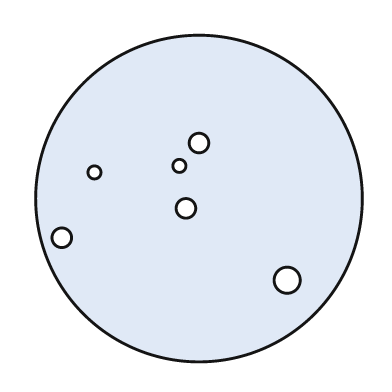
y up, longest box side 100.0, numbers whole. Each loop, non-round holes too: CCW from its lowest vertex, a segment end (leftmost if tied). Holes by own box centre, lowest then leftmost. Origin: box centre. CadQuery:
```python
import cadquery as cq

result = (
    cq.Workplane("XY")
    .moveTo(0.0, 0.0)
    .circle(50.0)
    .moveTo(27.0, -25.0)
    .circle(4.0)
    .moveTo(-42.0, -12.0)
    .circle(3.0)
    .moveTo(-4.0, -3.0)
    .circle(3.0)
    .moveTo(-32.0, 8.0)
    .circle(2.0)
    .moveTo(-6.0, 10.0)
    .circle(2.0)
    .moveTo(0.0, 17.0)
    .circle(3.0)
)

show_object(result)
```